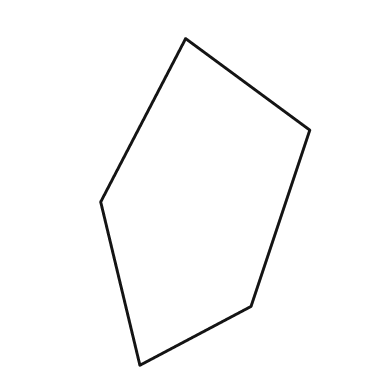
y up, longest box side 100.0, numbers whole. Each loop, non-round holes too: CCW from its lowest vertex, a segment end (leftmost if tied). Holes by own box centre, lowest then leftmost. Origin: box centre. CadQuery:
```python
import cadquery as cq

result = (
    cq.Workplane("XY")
    .moveTo(-20.0, -50.0)
    .lineTo(14.0, -32.0)
    .lineTo(32.0, 22.0)
    .lineTo(-6.0, 50.0)
    .lineTo(-32.0, 0.0)
    .close()
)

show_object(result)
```